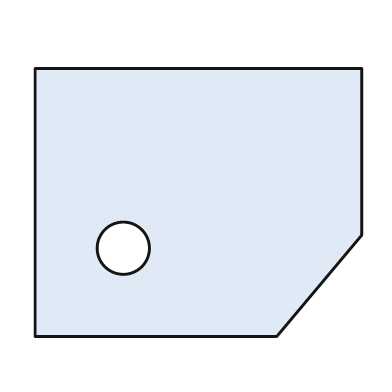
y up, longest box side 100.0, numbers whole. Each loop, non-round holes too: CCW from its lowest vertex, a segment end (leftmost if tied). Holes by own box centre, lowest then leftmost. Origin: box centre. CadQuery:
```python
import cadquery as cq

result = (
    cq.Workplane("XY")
    .moveTo(-50.0, -41.0)
    .lineTo(24.0, -41.0)
    .lineTo(50.0, -10.0)
    .lineTo(50.0, 41.0)
    .lineTo(-50.0, 41.0)
    .close()
    .moveTo(-23.0, -14.0)
    .circle(8.0)
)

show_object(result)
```